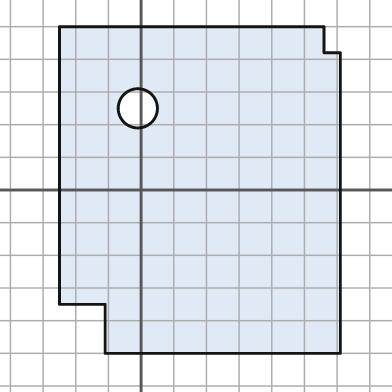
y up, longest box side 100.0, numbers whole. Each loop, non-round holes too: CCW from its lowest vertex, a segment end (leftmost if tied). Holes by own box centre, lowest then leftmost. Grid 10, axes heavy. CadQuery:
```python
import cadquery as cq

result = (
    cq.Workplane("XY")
    .moveTo(-11.0, -50.0)
    .lineTo(61.0, -50.0)
    .lineTo(61.0, 42.0)
    .lineTo(56.0, 42.0)
    .lineTo(56.0, 50.0)
    .lineTo(-25.0, 50.0)
    .lineTo(-25.0, -35.0)
    .lineTo(-11.0, -35.0)
    .close()
    .moveTo(-1.0, 25.0)
    .circle(6.0)
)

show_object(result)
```